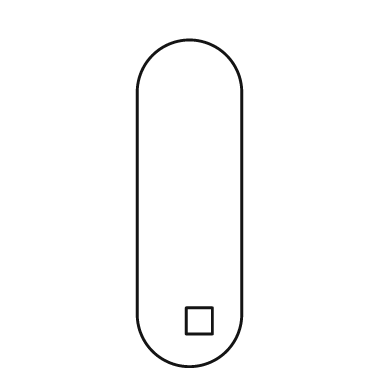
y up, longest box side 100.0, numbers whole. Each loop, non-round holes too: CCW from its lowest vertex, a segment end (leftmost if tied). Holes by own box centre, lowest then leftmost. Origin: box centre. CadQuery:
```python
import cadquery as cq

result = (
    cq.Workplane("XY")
    .moveTo(-16.0, -34.0)
    .threePointArc((0.0, -50.0), (16.0, -34.0))
    .lineTo(16.0, 34.0)
    .threePointArc((0.0, 50.0), (-16.0, 34.0))
    .close()
    .moveTo(-1.0, -40.0)
    .lineTo(7.0, -40.0)
    .lineTo(7.0, -32.0)
    .lineTo(-1.0, -32.0)
    .close()
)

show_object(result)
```